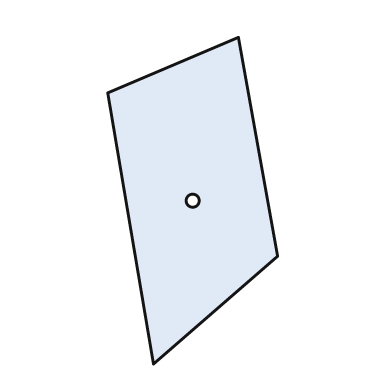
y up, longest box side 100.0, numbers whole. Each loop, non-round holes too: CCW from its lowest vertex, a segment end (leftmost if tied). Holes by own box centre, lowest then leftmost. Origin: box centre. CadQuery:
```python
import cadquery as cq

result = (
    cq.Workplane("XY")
    .moveTo(-12.0, -50.0)
    .lineTo(26.0, -17.0)
    .lineTo(14.0, 50.0)
    .lineTo(-26.0, 33.0)
    .close()
    .moveTo(0.0, 0.0)
    .circle(2.0)
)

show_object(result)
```